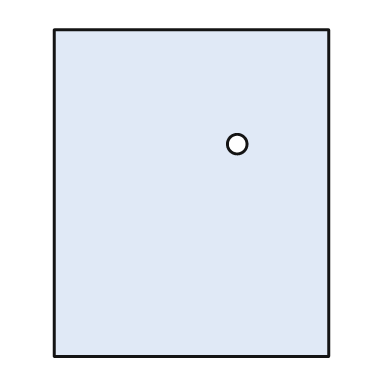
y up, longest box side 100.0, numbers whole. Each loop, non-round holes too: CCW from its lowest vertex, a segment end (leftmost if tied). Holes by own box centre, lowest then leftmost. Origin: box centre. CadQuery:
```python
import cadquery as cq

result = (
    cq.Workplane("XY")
    .moveTo(-42.0, -50.0)
    .lineTo(42.0, -50.0)
    .lineTo(42.0, 50.0)
    .lineTo(-42.0, 50.0)
    .close()
    .moveTo(14.0, 15.0)
    .circle(3.0)
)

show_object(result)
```